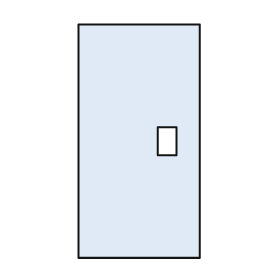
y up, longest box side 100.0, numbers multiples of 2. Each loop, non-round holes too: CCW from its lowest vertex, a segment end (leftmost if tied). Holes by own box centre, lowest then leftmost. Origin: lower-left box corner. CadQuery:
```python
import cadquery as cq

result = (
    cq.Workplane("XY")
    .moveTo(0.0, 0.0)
    .lineTo(52.0, 0.0)
    .lineTo(52.0, 100.0)
    .lineTo(0.0, 100.0)
    .close()
    .moveTo(34.0, 44.0)
    .lineTo(42.0, 44.0)
    .lineTo(42.0, 56.0)
    .lineTo(34.0, 56.0)
    .close()
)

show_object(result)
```